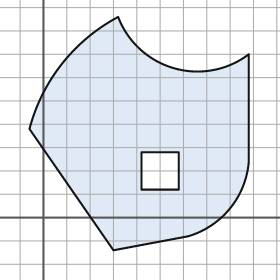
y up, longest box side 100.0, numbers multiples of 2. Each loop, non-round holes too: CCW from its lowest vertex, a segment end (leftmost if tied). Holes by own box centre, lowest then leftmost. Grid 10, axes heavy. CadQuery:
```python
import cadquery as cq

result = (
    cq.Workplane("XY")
    .moveTo(30.0, -14.0)
    .lineTo(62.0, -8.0)
    .threePointArc((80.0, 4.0), (88.0, 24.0))
    .lineTo(88.0, 70.0)
    .threePointArc((56.0, 64.0), (32.0, 86.0))
    .threePointArc((8.0, 66.0), (-6.0, 38.0))
    .close()
    .moveTo(42.0, 12.0)
    .lineTo(58.0, 12.0)
    .lineTo(58.0, 28.0)
    .lineTo(42.0, 28.0)
    .close()
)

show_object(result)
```